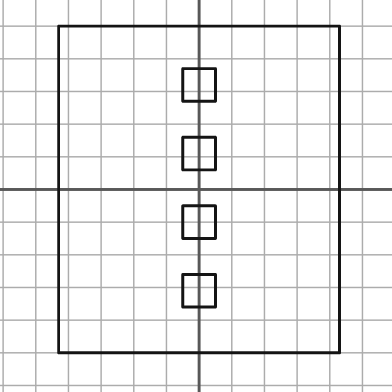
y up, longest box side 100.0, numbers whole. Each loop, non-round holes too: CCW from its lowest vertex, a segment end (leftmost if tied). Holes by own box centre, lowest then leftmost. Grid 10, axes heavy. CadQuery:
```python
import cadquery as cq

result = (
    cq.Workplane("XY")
    .moveTo(-43.0, -50.0)
    .lineTo(43.0, -50.0)
    .lineTo(43.0, 50.0)
    .lineTo(-43.0, 50.0)
    .close()
    .moveTo(-5.0, -36.0)
    .lineTo(5.0, -36.0)
    .lineTo(5.0, -26.0)
    .lineTo(-5.0, -26.0)
    .close()
    .moveTo(-5.0, -15.0)
    .lineTo(5.0, -15.0)
    .lineTo(5.0, -5.0)
    .lineTo(-5.0, -5.0)
    .close()
    .moveTo(-5.0, 6.0)
    .lineTo(5.0, 6.0)
    .lineTo(5.0, 16.0)
    .lineTo(-5.0, 16.0)
    .close()
    .moveTo(-5.0, 27.0)
    .lineTo(5.0, 27.0)
    .lineTo(5.0, 37.0)
    .lineTo(-5.0, 37.0)
    .close()
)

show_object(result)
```